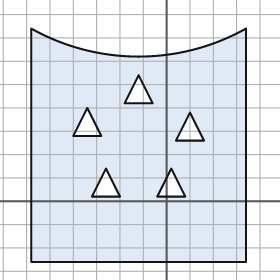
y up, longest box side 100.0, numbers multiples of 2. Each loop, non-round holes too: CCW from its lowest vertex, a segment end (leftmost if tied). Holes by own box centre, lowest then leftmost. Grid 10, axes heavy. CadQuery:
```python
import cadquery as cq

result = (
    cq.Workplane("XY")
    .moveTo(-58.0, -26.0)
    .lineTo(34.0, -26.0)
    .lineTo(34.0, 74.0)
    .threePointArc((-12.0, 62.0), (-58.0, 74.0))
    .close()
    .moveTo(-32.0, 2.0)
    .lineTo(-20.0, 2.0)
    .lineTo(-26.0, 14.0)
    .close()
    .moveTo(-4.0, 2.0)
    .lineTo(8.0, 2.0)
    .lineTo(2.0, 14.0)
    .close()
    .moveTo(4.0, 26.0)
    .lineTo(16.0, 26.0)
    .lineTo(10.0, 38.0)
    .close()
    .moveTo(-40.0, 28.0)
    .lineTo(-28.0, 28.0)
    .lineTo(-34.0, 40.0)
    .close()
    .moveTo(-18.0, 42.0)
    .lineTo(-6.0, 42.0)
    .lineTo(-12.0, 54.0)
    .close()
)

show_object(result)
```